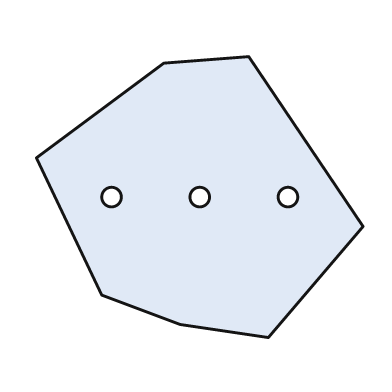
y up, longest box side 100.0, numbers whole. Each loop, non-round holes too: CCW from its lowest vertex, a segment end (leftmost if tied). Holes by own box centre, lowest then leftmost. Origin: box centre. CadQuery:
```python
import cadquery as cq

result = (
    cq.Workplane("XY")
    .moveTo(21.0, -43.0)
    .lineTo(50.0, -9.0)
    .lineTo(15.0, 43.0)
    .lineTo(-11.0, 41.0)
    .lineTo(-50.0, 12.0)
    .lineTo(-30.0, -30.0)
    .lineTo(-6.0, -39.0)
    .close()
    .moveTo(-27.0, 0.0)
    .circle(3.0)
    .moveTo(0.0, 0.0)
    .circle(3.0)
    .moveTo(27.0, 0.0)
    .circle(3.0)
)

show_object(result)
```